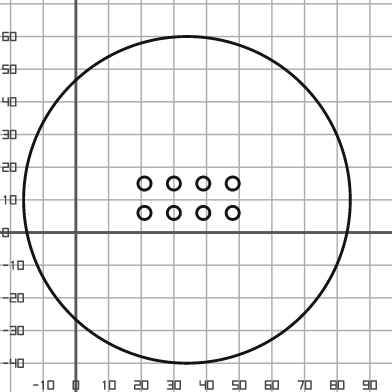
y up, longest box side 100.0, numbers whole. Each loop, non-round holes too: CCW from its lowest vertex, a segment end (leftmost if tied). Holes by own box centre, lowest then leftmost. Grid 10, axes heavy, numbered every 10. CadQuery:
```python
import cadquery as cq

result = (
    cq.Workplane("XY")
    .moveTo(34.0, 10.0)
    .circle(50.0)
    .moveTo(21.0, 6.0)
    .circle(2.0)
    .moveTo(30.0, 6.0)
    .circle(2.0)
    .moveTo(39.0, 6.0)
    .circle(2.0)
    .moveTo(48.0, 6.0)
    .circle(2.0)
    .moveTo(21.0, 15.0)
    .circle(2.0)
    .moveTo(30.0, 15.0)
    .circle(2.0)
    .moveTo(39.0, 15.0)
    .circle(2.0)
    .moveTo(48.0, 15.0)
    .circle(2.0)
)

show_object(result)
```